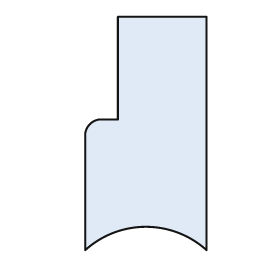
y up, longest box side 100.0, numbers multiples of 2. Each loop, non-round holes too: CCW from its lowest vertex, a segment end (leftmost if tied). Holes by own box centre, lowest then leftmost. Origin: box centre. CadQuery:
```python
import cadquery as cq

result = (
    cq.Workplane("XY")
    .moveTo(-26.0, -50.0)
    .threePointArc((0.0, -40.0), (26.0, -50.0))
    .lineTo(26.0, 50.0)
    .lineTo(-12.0, 50.0)
    .lineTo(-12.0, 6.0)
    .lineTo(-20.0, 6.0)
    .threePointArc((-24.0, 4.0), (-26.0, 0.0))
    .close()
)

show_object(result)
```